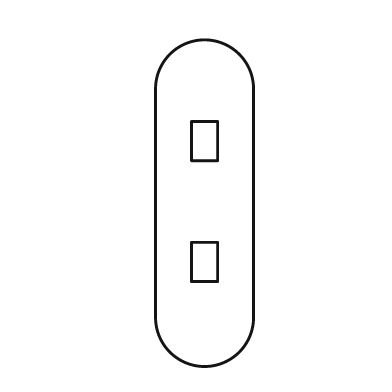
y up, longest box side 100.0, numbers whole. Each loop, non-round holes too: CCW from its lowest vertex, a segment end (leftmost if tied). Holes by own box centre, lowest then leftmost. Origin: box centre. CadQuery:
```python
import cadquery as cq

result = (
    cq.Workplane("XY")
    .moveTo(-15.0, -35.0)
    .threePointArc((0.0, -50.0), (15.0, -35.0))
    .lineTo(15.0, 35.0)
    .threePointArc((0.0, 50.0), (-15.0, 35.0))
    .close()
    .moveTo(-4.0, -24.0)
    .lineTo(4.0, -24.0)
    .lineTo(4.0, -12.0)
    .lineTo(-4.0, -12.0)
    .close()
    .moveTo(-4.0, 13.0)
    .lineTo(4.0, 13.0)
    .lineTo(4.0, 25.0)
    .lineTo(-4.0, 25.0)
    .close()
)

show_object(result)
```